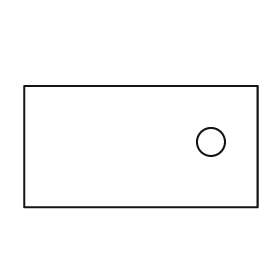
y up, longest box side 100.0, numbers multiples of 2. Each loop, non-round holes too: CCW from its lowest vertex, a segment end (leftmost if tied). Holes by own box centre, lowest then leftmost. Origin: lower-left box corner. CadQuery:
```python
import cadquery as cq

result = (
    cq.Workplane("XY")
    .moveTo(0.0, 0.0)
    .lineTo(100.0, 0.0)
    .lineTo(100.0, 52.0)
    .lineTo(0.0, 52.0)
    .close()
    .moveTo(80.0, 28.0)
    .circle(6.0)
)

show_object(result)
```